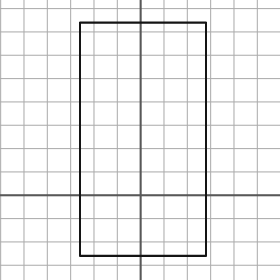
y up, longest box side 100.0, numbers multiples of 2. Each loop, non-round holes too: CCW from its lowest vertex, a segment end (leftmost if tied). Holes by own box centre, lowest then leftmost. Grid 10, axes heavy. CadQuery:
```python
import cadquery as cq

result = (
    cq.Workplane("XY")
    .moveTo(-26.0, -26.0)
    .lineTo(28.0, -26.0)
    .lineTo(28.0, 74.0)
    .lineTo(-26.0, 74.0)
    .close()
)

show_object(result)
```